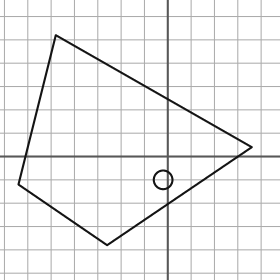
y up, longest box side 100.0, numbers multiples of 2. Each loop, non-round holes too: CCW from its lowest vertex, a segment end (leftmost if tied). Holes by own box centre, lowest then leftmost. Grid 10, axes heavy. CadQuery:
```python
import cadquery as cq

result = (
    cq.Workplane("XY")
    .moveTo(-26.0, -38.0)
    .lineTo(36.0, 4.0)
    .lineTo(-48.0, 52.0)
    .lineTo(-64.0, -12.0)
    .close()
    .moveTo(-2.0, -10.0)
    .circle(4.0)
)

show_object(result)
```